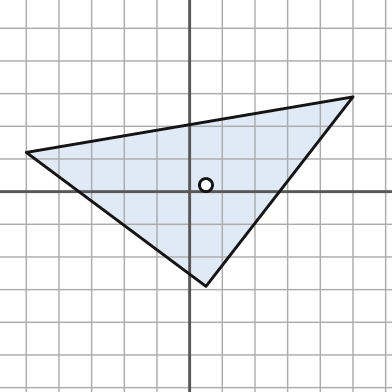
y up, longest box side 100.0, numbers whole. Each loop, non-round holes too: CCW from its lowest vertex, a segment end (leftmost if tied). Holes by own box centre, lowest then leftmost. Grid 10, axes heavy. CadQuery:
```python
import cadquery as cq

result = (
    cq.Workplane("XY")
    .moveTo(5.0, -29.0)
    .lineTo(50.0, 29.0)
    .lineTo(-50.0, 12.0)
    .close()
    .moveTo(5.0, 2.0)
    .circle(2.0)
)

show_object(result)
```